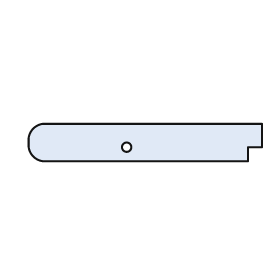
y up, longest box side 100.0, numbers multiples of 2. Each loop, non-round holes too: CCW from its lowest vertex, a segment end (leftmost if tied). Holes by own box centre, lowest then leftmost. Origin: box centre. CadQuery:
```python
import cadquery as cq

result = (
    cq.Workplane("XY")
    .moveTo(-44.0, -8.0)
    .lineTo(44.0, -8.0)
    .lineTo(44.0, -2.0)
    .lineTo(50.0, -2.0)
    .lineTo(50.0, 8.0)
    .lineTo(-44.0, 8.0)
    .threePointArc((-48.0, 6.0), (-50.0, 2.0))
    .lineTo(-50.0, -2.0)
    .threePointArc((-48.0, -6.0), (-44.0, -8.0))
    .close()
    .moveTo(-8.0, -2.0)
    .circle(2.0)
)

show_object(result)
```